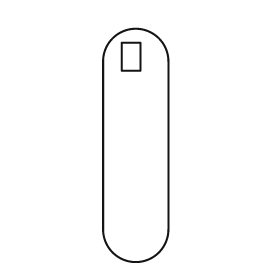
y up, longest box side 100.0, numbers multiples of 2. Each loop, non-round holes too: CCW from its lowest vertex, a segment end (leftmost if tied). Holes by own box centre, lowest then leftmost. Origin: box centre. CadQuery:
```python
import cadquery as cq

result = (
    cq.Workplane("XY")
    .moveTo(-14.0, -36.0)
    .threePointArc((0.0, -50.0), (14.0, -36.0))
    .lineTo(14.0, 36.0)
    .threePointArc((0.0, 50.0), (-14.0, 36.0))
    .close()
    .moveTo(-6.0, 32.0)
    .lineTo(2.0, 32.0)
    .lineTo(2.0, 44.0)
    .lineTo(-6.0, 44.0)
    .close()
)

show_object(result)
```